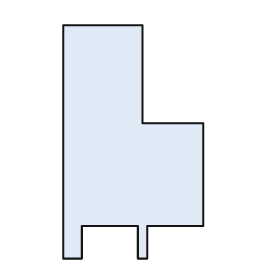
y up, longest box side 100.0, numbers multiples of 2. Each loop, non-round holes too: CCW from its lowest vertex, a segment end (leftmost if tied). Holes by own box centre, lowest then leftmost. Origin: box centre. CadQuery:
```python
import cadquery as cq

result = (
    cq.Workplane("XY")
    .moveTo(-30.0, -50.0)
    .lineTo(-22.0, -50.0)
    .lineTo(-22.0, -36.0)
    .lineTo(2.0, -36.0)
    .lineTo(2.0, -50.0)
    .lineTo(6.0, -50.0)
    .lineTo(6.0, -36.0)
    .lineTo(30.0, -36.0)
    .lineTo(30.0, 8.0)
    .lineTo(4.0, 8.0)
    .lineTo(4.0, 50.0)
    .lineTo(-30.0, 50.0)
    .close()
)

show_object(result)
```